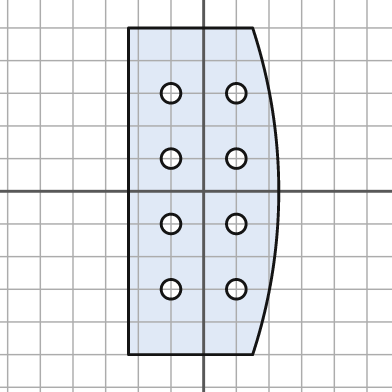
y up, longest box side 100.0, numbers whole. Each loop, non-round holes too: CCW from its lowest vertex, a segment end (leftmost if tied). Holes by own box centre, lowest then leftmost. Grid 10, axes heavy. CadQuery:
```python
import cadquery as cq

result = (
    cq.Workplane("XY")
    .moveTo(-23.0, -50.0)
    .lineTo(15.0, -50.0)
    .threePointArc((23.0, 0.0), (15.0, 50.0))
    .lineTo(-23.0, 50.0)
    .close()
    .moveTo(-10.0, -30.0)
    .circle(3.0)
    .moveTo(10.0, -30.0)
    .circle(3.0)
    .moveTo(-10.0, -10.0)
    .circle(3.0)
    .moveTo(10.0, -10.0)
    .circle(3.0)
    .moveTo(-10.0, 10.0)
    .circle(3.0)
    .moveTo(10.0, 10.0)
    .circle(3.0)
    .moveTo(-10.0, 30.0)
    .circle(3.0)
    .moveTo(10.0, 30.0)
    .circle(3.0)
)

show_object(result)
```